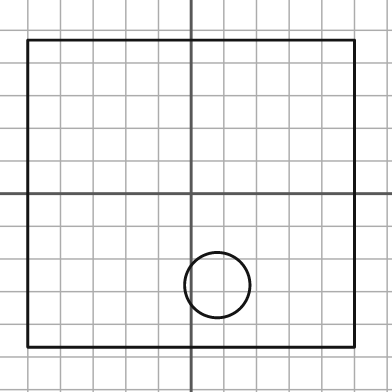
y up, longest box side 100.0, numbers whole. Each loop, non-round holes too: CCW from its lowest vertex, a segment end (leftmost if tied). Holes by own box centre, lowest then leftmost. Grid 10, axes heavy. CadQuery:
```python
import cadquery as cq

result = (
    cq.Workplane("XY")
    .moveTo(-50.0, -47.0)
    .lineTo(50.0, -47.0)
    .lineTo(50.0, 47.0)
    .lineTo(-50.0, 47.0)
    .close()
    .moveTo(8.0, -28.0)
    .circle(10.0)
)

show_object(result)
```